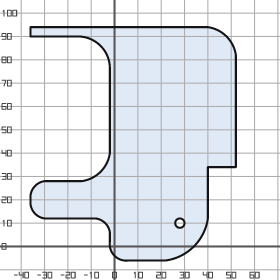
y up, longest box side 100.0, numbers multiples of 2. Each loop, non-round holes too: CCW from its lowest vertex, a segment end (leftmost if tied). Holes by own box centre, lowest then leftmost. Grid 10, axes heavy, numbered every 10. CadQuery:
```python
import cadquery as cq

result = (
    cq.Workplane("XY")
    .moveTo(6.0, -6.0)
    .lineTo(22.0, -6.0)
    .threePointArc((34.0, 0.0), (40.0, 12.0))
    .lineTo(40.0, 34.0)
    .lineTo(52.0, 34.0)
    .lineTo(52.0, 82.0)
    .threePointArc((48.0, 90.0), (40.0, 94.0))
    .lineTo(-36.0, 94.0)
    .lineTo(-36.0, 90.0)
    .lineTo(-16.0, 90.0)
    .threePointArc((-6.0, 86.0), (-2.0, 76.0))
    .lineTo(-2.0, 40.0)
    .threePointArc((-6.0, 32.0), (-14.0, 28.0))
    .lineTo(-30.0, 28.0)
    .threePointArc((-34.0, 26.0), (-36.0, 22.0))
    .lineTo(-36.0, 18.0)
    .threePointArc((-34.0, 14.0), (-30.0, 12.0))
    .lineTo(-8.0, 12.0)
    .threePointArc((-4.0, 10.0), (-2.0, 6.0))
    .lineTo(-2.0, 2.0)
    .threePointArc((0.0, -4.0), (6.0, -6.0))
    .close()
    .moveTo(28.0, 10.0)
    .circle(2.0)
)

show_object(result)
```